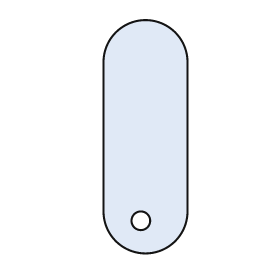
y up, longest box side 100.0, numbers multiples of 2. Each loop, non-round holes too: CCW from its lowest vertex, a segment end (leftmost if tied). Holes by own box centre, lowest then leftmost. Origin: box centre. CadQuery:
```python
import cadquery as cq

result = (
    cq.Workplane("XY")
    .moveTo(-18.0, -32.0)
    .threePointArc((0.0, -50.0), (18.0, -32.0))
    .lineTo(18.0, 32.0)
    .threePointArc((0.0, 50.0), (-18.0, 32.0))
    .close()
    .moveTo(-2.0, -36.0)
    .circle(4.0)
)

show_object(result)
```